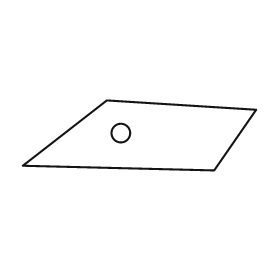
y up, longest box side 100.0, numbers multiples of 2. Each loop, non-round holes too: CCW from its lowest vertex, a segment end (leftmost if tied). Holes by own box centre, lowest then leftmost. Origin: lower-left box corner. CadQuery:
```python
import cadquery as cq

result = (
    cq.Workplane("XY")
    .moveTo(82.0, 0.0)
    .lineTo(100.0, 26.0)
    .lineTo(36.0, 30.0)
    .lineTo(0.0, 2.0)
    .close()
    .moveTo(42.0, 16.0)
    .circle(4.0)
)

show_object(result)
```